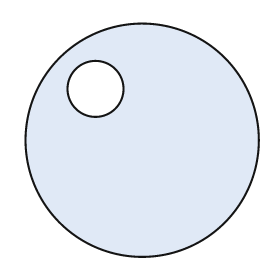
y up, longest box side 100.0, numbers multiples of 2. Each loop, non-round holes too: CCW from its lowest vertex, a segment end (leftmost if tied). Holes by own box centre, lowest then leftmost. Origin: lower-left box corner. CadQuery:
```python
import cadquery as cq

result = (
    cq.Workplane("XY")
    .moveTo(50.0, 50.0)
    .circle(50.0)
    .moveTo(30.0, 72.0)
    .circle(12.0)
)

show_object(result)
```